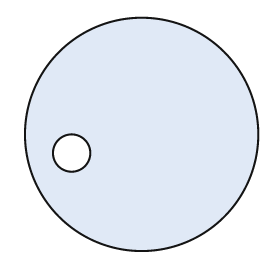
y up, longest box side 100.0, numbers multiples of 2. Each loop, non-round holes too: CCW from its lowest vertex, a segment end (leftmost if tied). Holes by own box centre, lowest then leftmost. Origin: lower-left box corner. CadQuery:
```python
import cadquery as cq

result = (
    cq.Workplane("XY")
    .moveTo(50.0, 50.0)
    .circle(50.0)
    .moveTo(20.0, 42.0)
    .circle(8.0)
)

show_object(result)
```